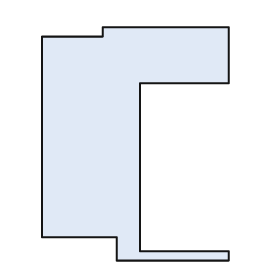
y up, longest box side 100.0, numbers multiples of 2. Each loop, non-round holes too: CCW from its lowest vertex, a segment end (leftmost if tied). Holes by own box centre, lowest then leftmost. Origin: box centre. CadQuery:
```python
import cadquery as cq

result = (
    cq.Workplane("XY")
    .moveTo(-8.0, -50.0)
    .lineTo(40.0, -50.0)
    .lineTo(40.0, -46.0)
    .lineTo(2.0, -46.0)
    .lineTo(2.0, 26.0)
    .lineTo(40.0, 26.0)
    .lineTo(40.0, 50.0)
    .lineTo(-14.0, 50.0)
    .lineTo(-14.0, 46.0)
    .lineTo(-40.0, 46.0)
    .lineTo(-40.0, -40.0)
    .lineTo(-8.0, -40.0)
    .close()
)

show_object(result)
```